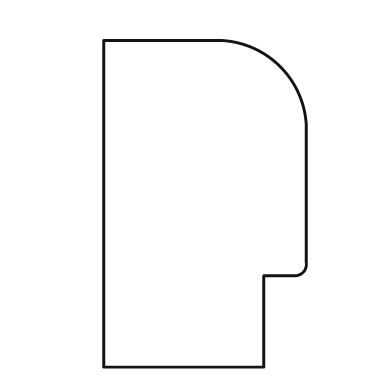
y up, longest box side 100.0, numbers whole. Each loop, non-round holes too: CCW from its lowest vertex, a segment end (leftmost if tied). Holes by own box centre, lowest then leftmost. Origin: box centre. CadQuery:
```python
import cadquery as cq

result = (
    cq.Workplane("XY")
    .moveTo(-31.0, -50.0)
    .lineTo(18.0, -50.0)
    .lineTo(18.0, -22.0)
    .lineTo(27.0, -22.0)
    .threePointArc((30.0, -21.0), (31.0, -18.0))
    .lineTo(31.0, 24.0)
    .threePointArc((23.0, 42.0), (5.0, 50.0))
    .lineTo(-31.0, 50.0)
    .close()
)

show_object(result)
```